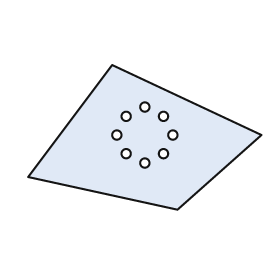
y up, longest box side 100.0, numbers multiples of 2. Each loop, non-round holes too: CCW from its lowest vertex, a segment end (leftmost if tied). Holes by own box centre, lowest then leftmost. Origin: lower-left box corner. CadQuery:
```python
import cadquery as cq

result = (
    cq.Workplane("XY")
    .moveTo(64.0, 0.0)
    .lineTo(100.0, 32.0)
    .lineTo(36.0, 62.0)
    .lineTo(0.0, 14.0)
    .close()
    .moveTo(50.0, 20.0)
    .circle(2.0)
    .moveTo(42.0, 24.0)
    .circle(2.0)
    .moveTo(58.0, 24.0)
    .circle(2.0)
    .moveTo(38.0, 32.0)
    .circle(2.0)
    .moveTo(62.0, 32.0)
    .circle(2.0)
    .moveTo(42.0, 40.0)
    .circle(2.0)
    .moveTo(58.0, 40.0)
    .circle(2.0)
    .moveTo(50.0, 44.0)
    .circle(2.0)
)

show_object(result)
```